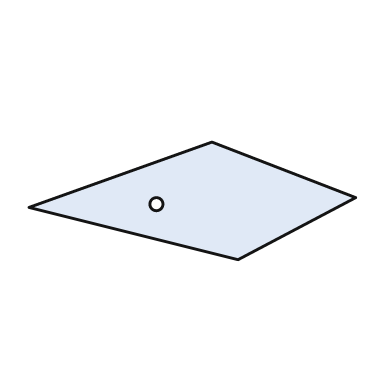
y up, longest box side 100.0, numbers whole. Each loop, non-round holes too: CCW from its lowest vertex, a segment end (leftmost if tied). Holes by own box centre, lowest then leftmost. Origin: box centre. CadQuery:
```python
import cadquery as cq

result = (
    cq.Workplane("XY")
    .moveTo(14.0, -18.0)
    .lineTo(50.0, 1.0)
    .lineTo(6.0, 18.0)
    .lineTo(-50.0, -2.0)
    .close()
    .moveTo(-11.0, -1.0)
    .circle(2.0)
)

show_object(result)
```